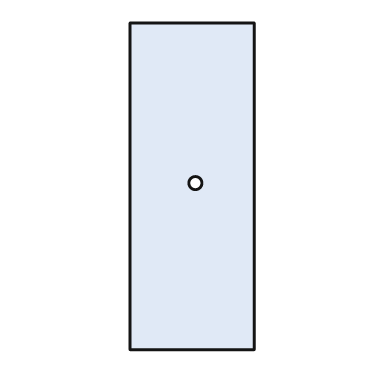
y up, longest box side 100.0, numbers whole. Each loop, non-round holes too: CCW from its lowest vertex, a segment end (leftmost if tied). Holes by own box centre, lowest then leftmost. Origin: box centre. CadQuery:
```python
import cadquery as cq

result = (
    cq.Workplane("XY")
    .moveTo(-19.0, -50.0)
    .lineTo(19.0, -50.0)
    .lineTo(19.0, 50.0)
    .lineTo(-19.0, 50.0)
    .close()
    .moveTo(1.0, 1.0)
    .circle(2.0)
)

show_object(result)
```